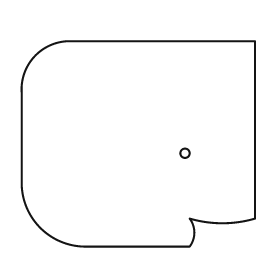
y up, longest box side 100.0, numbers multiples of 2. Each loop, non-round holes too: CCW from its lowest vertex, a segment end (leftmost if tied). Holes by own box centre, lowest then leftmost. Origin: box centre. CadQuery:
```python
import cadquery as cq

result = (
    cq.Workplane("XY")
    .moveTo(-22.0, -44.0)
    .lineTo(22.0, -44.0)
    .threePointArc((24.0, -38.0), (22.0, -32.0))
    .threePointArc((36.0, -34.0), (50.0, -32.0))
    .lineTo(50.0, 44.0)
    .lineTo(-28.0, 44.0)
    .threePointArc((-44.0, 38.0), (-50.0, 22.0))
    .lineTo(-50.0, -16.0)
    .threePointArc((-42.0, -36.0), (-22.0, -44.0))
    .close()
    .moveTo(20.0, -4.0)
    .circle(2.0)
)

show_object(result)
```